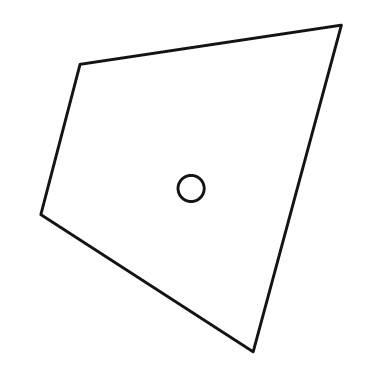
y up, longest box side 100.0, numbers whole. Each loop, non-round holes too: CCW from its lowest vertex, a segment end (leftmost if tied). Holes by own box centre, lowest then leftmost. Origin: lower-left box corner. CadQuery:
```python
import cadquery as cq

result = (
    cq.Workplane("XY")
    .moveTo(65.0, 0.0)
    .lineTo(92.0, 100.0)
    .lineTo(12.0, 88.0)
    .lineTo(0.0, 42.0)
    .close()
    .moveTo(46.0, 50.0)
    .circle(4.0)
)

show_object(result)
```